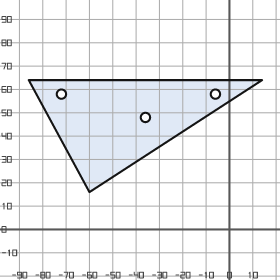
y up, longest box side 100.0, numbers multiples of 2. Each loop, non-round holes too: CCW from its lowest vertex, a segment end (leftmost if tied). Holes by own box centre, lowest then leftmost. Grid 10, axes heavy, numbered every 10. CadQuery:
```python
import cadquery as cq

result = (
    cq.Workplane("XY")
    .moveTo(-60.0, 16.0)
    .lineTo(14.0, 64.0)
    .lineTo(-86.0, 64.0)
    .close()
    .moveTo(-36.0, 48.0)
    .circle(2.0)
    .moveTo(-72.0, 58.0)
    .circle(2.0)
    .moveTo(-6.0, 58.0)
    .circle(2.0)
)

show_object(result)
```